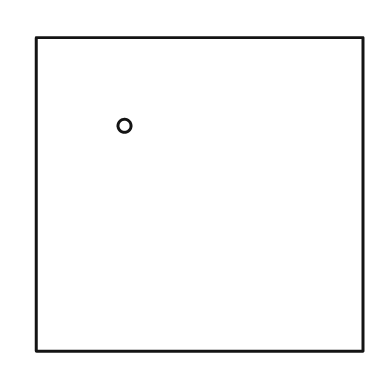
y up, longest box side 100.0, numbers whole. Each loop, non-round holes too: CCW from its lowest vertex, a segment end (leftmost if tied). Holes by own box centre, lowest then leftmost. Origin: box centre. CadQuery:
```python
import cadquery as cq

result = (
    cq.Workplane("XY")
    .moveTo(-50.0, -48.0)
    .lineTo(50.0, -48.0)
    .lineTo(50.0, 48.0)
    .lineTo(-50.0, 48.0)
    .close()
    .moveTo(-23.0, 21.0)
    .circle(2.0)
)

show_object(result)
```